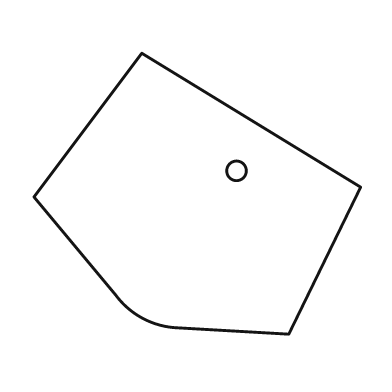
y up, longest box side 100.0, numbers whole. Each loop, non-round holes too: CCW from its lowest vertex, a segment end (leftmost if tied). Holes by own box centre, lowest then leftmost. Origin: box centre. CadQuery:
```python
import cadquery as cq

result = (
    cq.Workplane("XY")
    .moveTo(28.0, -43.0)
    .lineTo(50.0, 2.0)
    .lineTo(-17.0, 43.0)
    .lineTo(-50.0, -1.0)
    .lineTo(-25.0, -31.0)
    .threePointArc((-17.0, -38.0), (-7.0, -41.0))
    .close()
    .moveTo(12.0, 7.0)
    .circle(3.0)
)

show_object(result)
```